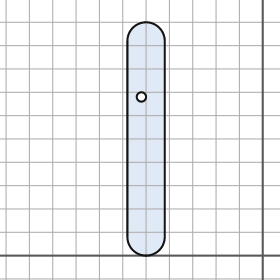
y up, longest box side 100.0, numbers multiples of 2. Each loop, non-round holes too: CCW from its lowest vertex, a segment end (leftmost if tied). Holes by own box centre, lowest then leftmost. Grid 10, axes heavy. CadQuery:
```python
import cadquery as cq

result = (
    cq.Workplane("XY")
    .moveTo(-58.0, 8.0)
    .threePointArc((-50.0, 0.0), (-42.0, 8.0))
    .lineTo(-42.0, 92.0)
    .threePointArc((-50.0, 100.0), (-58.0, 92.0))
    .close()
    .moveTo(-52.0, 68.0)
    .circle(2.0)
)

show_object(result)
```